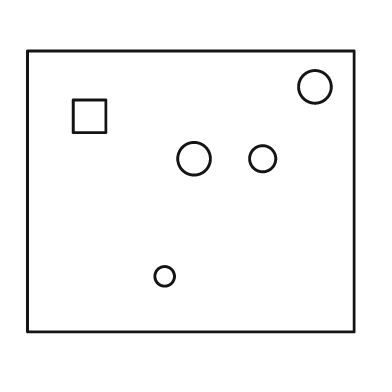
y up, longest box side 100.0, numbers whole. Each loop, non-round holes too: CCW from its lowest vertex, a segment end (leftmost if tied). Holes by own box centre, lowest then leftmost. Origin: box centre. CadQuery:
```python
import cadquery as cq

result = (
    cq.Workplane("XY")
    .moveTo(-50.0, -43.0)
    .lineTo(50.0, -43.0)
    .lineTo(50.0, 43.0)
    .lineTo(-50.0, 43.0)
    .close()
    .moveTo(-8.0, -26.0)
    .circle(3.0)
    .moveTo(1.0, 10.0)
    .circle(5.0)
    .moveTo(22.0, 10.0)
    .circle(4.0)
    .moveTo(-36.0, 18.0)
    .lineTo(-26.0, 18.0)
    .lineTo(-26.0, 28.0)
    .lineTo(-36.0, 28.0)
    .close()
    .moveTo(38.0, 32.0)
    .circle(5.0)
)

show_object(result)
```